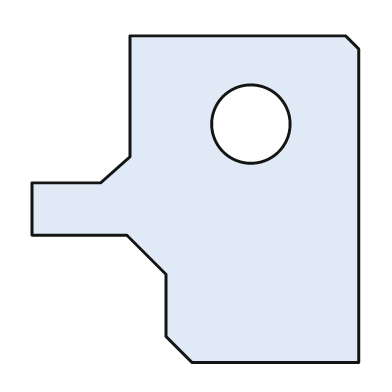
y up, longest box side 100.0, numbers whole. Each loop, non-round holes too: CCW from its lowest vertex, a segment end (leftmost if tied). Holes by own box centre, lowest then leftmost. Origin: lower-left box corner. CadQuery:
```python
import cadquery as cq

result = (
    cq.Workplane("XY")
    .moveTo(49.0, 0.0)
    .lineTo(100.0, 0.0)
    .lineTo(100.0, 96.0)
    .lineTo(96.0, 100.0)
    .lineTo(30.0, 100.0)
    .lineTo(30.0, 63.0)
    .lineTo(21.0, 55.0)
    .lineTo(0.0, 55.0)
    .lineTo(0.0, 39.0)
    .lineTo(29.0, 39.0)
    .lineTo(41.0, 27.0)
    .lineTo(41.0, 8.0)
    .close()
    .moveTo(67.0, 73.0)
    .circle(12.0)
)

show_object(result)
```